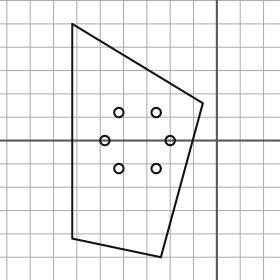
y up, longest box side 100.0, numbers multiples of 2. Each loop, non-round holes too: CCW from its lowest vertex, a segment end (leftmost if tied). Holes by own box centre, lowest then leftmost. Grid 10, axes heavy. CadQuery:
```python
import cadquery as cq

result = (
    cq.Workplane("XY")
    .moveTo(-24.0, -50.0)
    .lineTo(-6.0, 16.0)
    .lineTo(-62.0, 50.0)
    .lineTo(-62.0, -42.0)
    .close()
    .moveTo(-42.0, -12.0)
    .circle(2.0)
    .moveTo(-26.0, -12.0)
    .circle(2.0)
    .moveTo(-48.0, 0.0)
    .circle(2.0)
    .moveTo(-20.0, 0.0)
    .circle(2.0)
    .moveTo(-42.0, 12.0)
    .circle(2.0)
    .moveTo(-26.0, 12.0)
    .circle(2.0)
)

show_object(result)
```